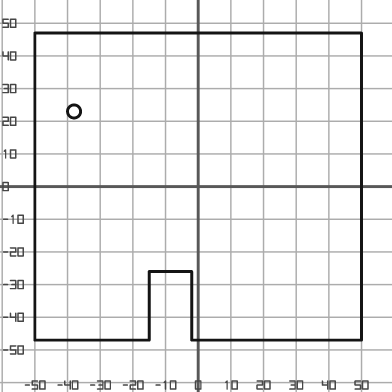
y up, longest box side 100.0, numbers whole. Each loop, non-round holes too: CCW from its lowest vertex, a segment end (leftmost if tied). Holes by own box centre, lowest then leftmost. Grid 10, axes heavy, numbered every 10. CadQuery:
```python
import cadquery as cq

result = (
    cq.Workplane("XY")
    .moveTo(-50.0, -47.0)
    .lineTo(-15.0, -47.0)
    .lineTo(-15.0, -26.0)
    .lineTo(-2.0, -26.0)
    .lineTo(-2.0, -47.0)
    .lineTo(50.0, -47.0)
    .lineTo(50.0, 47.0)
    .lineTo(-50.0, 47.0)
    .close()
    .moveTo(-38.0, 23.0)
    .circle(2.0)
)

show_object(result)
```